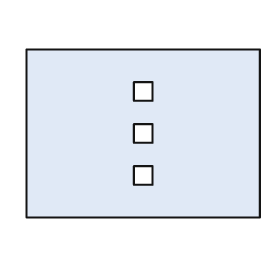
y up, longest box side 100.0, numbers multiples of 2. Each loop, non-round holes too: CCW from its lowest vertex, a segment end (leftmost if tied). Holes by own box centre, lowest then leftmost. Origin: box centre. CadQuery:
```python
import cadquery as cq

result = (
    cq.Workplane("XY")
    .moveTo(-50.0, -36.0)
    .lineTo(50.0, -36.0)
    .lineTo(50.0, 36.0)
    .lineTo(-50.0, 36.0)
    .close()
    .moveTo(-4.0, -22.0)
    .lineTo(4.0, -22.0)
    .lineTo(4.0, -14.0)
    .lineTo(-4.0, -14.0)
    .close()
    .moveTo(-4.0, -4.0)
    .lineTo(4.0, -4.0)
    .lineTo(4.0, 4.0)
    .lineTo(-4.0, 4.0)
    .close()
    .moveTo(-4.0, 14.0)
    .lineTo(4.0, 14.0)
    .lineTo(4.0, 22.0)
    .lineTo(-4.0, 22.0)
    .close()
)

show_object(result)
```